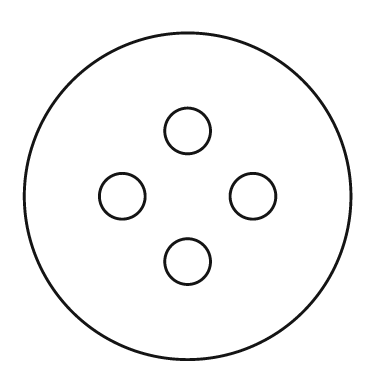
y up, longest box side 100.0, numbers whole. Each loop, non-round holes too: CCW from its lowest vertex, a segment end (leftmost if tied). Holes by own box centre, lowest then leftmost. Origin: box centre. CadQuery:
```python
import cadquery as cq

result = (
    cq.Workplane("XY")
    .moveTo(0.0, 0.0)
    .circle(50.0)
    .moveTo(0.0, -20.0)
    .circle(7.0)
    .moveTo(-20.0, 0.0)
    .circle(7.0)
    .moveTo(20.0, 0.0)
    .circle(7.0)
    .moveTo(0.0, 20.0)
    .circle(7.0)
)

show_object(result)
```